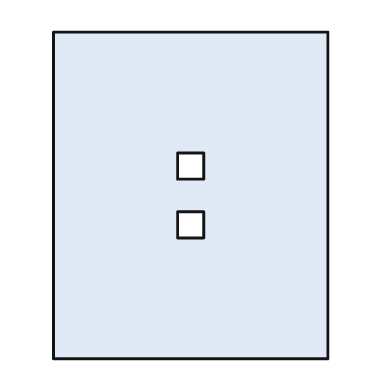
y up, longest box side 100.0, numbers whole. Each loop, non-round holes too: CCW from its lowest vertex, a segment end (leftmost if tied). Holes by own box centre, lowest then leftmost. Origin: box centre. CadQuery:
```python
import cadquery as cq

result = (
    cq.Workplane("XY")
    .moveTo(-42.0, -50.0)
    .lineTo(42.0, -50.0)
    .lineTo(42.0, 50.0)
    .lineTo(-42.0, 50.0)
    .close()
    .moveTo(-4.0, -13.0)
    .lineTo(4.0, -13.0)
    .lineTo(4.0, -5.0)
    .lineTo(-4.0, -5.0)
    .close()
    .moveTo(-4.0, 5.0)
    .lineTo(4.0, 5.0)
    .lineTo(4.0, 13.0)
    .lineTo(-4.0, 13.0)
    .close()
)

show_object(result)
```